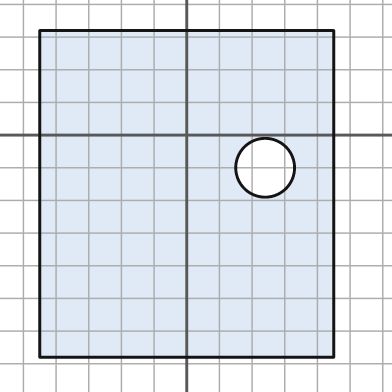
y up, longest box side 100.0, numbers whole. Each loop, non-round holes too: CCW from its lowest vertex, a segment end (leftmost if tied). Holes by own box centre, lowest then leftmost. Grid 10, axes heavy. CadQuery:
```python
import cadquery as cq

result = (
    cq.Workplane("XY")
    .moveTo(-45.0, -68.0)
    .lineTo(45.0, -68.0)
    .lineTo(45.0, 32.0)
    .lineTo(-45.0, 32.0)
    .close()
    .moveTo(24.0, -10.0)
    .circle(9.0)
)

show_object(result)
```